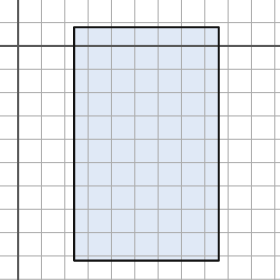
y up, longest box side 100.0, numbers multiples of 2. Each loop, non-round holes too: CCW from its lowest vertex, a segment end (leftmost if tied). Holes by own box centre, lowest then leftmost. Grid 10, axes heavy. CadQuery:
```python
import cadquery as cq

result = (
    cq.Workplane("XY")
    .moveTo(24.0, -92.0)
    .lineTo(86.0, -92.0)
    .lineTo(86.0, 8.0)
    .lineTo(24.0, 8.0)
    .close()
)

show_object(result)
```